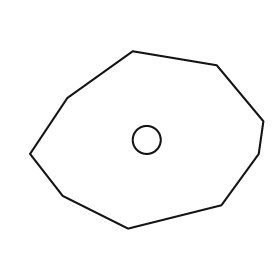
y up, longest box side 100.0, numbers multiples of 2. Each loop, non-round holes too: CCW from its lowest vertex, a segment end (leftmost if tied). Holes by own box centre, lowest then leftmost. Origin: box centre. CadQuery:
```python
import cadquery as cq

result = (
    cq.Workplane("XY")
    .moveTo(-8.0, -38.0)
    .lineTo(32.0, -28.0)
    .lineTo(48.0, -6.0)
    .lineTo(50.0, 8.0)
    .lineTo(30.0, 32.0)
    .lineTo(-6.0, 38.0)
    .lineTo(-34.0, 18.0)
    .lineTo(-50.0, -6.0)
    .lineTo(-36.0, -24.0)
    .close()
    .moveTo(0.0, 0.0)
    .circle(6.0)
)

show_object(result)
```